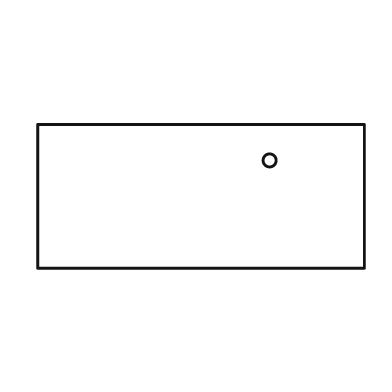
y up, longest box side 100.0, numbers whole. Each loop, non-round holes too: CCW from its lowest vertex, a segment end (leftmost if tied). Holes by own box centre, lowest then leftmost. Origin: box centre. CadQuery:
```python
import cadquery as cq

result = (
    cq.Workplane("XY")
    .moveTo(-50.0, -22.0)
    .lineTo(50.0, -22.0)
    .lineTo(50.0, 22.0)
    .lineTo(-50.0, 22.0)
    .close()
    .moveTo(21.0, 11.0)
    .circle(2.0)
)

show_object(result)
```